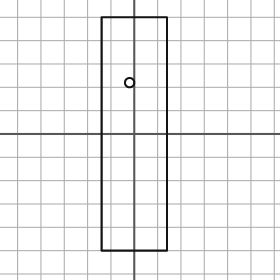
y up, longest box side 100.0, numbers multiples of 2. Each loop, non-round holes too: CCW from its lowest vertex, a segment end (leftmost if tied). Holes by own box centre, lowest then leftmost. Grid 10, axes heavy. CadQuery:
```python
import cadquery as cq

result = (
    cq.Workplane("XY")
    .moveTo(-14.0, -50.0)
    .lineTo(14.0, -50.0)
    .lineTo(14.0, 50.0)
    .lineTo(-14.0, 50.0)
    .close()
    .moveTo(-2.0, 22.0)
    .circle(2.0)
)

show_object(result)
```